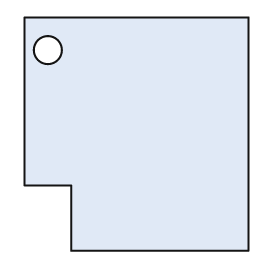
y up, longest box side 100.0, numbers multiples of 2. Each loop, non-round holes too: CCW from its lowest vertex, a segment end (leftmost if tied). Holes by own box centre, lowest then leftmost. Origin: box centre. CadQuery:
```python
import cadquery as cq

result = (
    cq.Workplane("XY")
    .moveTo(-28.0, -50.0)
    .lineTo(48.0, -50.0)
    .lineTo(48.0, 50.0)
    .lineTo(-48.0, 50.0)
    .lineTo(-48.0, -22.0)
    .lineTo(-28.0, -22.0)
    .close()
    .moveTo(-38.0, 36.0)
    .circle(6.0)
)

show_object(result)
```